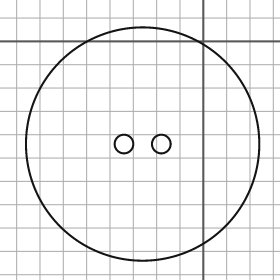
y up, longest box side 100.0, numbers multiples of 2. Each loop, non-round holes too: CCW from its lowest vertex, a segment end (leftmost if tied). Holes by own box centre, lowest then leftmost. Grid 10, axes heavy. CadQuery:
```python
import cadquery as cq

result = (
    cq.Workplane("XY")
    .moveTo(-26.0, -44.0)
    .circle(50.0)
    .moveTo(-34.0, -44.0)
    .circle(4.0)
    .moveTo(-18.0, -44.0)
    .circle(4.0)
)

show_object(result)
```